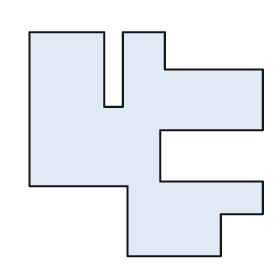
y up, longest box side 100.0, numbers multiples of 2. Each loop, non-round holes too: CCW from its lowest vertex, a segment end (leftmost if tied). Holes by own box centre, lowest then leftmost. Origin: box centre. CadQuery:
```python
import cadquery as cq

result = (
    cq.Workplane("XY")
    .moveTo(-8.0, -48.0)
    .lineTo(32.0, -48.0)
    .lineTo(32.0, -30.0)
    .lineTo(50.0, -30.0)
    .lineTo(50.0, -16.0)
    .lineTo(6.0, -16.0)
    .lineTo(6.0, 6.0)
    .lineTo(50.0, 6.0)
    .lineTo(50.0, 32.0)
    .lineTo(8.0, 32.0)
    .lineTo(8.0, 48.0)
    .lineTo(-10.0, 48.0)
    .lineTo(-10.0, 16.0)
    .lineTo(-18.0, 16.0)
    .lineTo(-18.0, 48.0)
    .lineTo(-50.0, 48.0)
    .lineTo(-50.0, -18.0)
    .lineTo(-8.0, -18.0)
    .close()
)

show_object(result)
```